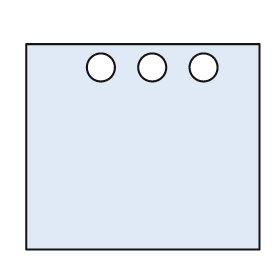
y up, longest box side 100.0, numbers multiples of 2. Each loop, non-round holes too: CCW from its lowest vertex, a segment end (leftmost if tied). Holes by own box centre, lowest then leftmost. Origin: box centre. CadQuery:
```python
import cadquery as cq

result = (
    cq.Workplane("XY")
    .moveTo(-50.0, -44.0)
    .lineTo(50.0, -44.0)
    .lineTo(50.0, 44.0)
    .lineTo(-50.0, 44.0)
    .close()
    .moveTo(-18.0, 34.0)
    .circle(6.0)
    .moveTo(4.0, 34.0)
    .circle(6.0)
    .moveTo(26.0, 34.0)
    .circle(6.0)
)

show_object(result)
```